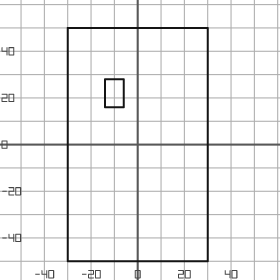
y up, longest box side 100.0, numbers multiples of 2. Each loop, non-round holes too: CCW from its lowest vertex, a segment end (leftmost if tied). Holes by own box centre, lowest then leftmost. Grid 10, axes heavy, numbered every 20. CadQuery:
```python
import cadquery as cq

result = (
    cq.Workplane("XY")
    .moveTo(-30.0, -50.0)
    .lineTo(30.0, -50.0)
    .lineTo(30.0, 50.0)
    .lineTo(-30.0, 50.0)
    .close()
    .moveTo(-14.0, 16.0)
    .lineTo(-6.0, 16.0)
    .lineTo(-6.0, 28.0)
    .lineTo(-14.0, 28.0)
    .close()
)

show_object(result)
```